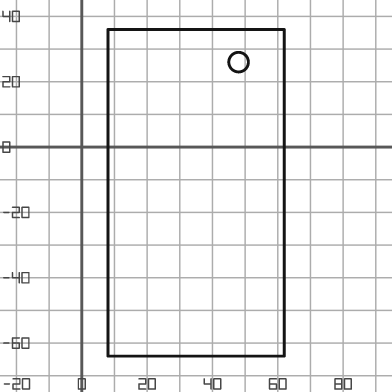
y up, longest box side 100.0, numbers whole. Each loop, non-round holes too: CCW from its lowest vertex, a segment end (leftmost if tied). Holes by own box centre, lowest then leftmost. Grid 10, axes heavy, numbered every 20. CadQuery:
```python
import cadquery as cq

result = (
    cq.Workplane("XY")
    .moveTo(8.0, -64.0)
    .lineTo(62.0, -64.0)
    .lineTo(62.0, 36.0)
    .lineTo(8.0, 36.0)
    .close()
    .moveTo(48.0, 26.0)
    .circle(3.0)
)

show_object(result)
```